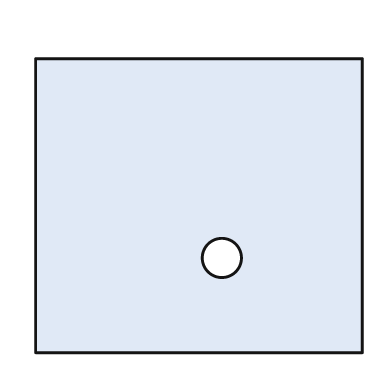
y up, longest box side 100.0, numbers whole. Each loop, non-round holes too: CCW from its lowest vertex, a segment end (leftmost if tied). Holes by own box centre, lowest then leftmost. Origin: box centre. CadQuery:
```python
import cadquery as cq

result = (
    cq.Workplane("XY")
    .moveTo(-50.0, -45.0)
    .lineTo(50.0, -45.0)
    .lineTo(50.0, 45.0)
    .lineTo(-50.0, 45.0)
    .close()
    .moveTo(7.0, -16.0)
    .circle(6.0)
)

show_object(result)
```